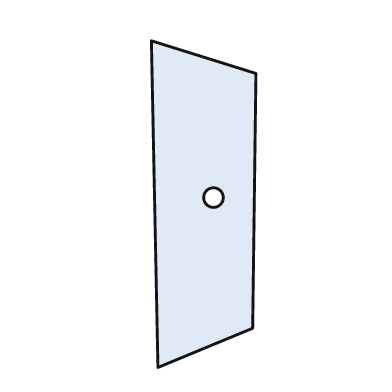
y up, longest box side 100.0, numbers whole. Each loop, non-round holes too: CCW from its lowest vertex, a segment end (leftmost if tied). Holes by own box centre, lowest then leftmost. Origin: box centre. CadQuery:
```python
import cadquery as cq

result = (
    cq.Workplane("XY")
    .moveTo(-14.0, -50.0)
    .lineTo(15.0, -38.0)
    .lineTo(16.0, 40.0)
    .lineTo(-16.0, 50.0)
    .close()
    .moveTo(3.0, 2.0)
    .circle(3.0)
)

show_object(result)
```